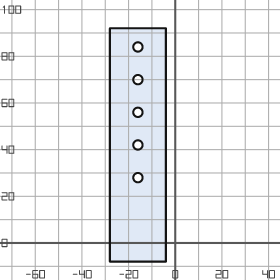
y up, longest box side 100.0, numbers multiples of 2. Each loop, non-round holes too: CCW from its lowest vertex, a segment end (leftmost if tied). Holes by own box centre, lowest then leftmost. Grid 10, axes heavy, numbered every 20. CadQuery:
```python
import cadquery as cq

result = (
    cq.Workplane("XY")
    .moveTo(-28.0, -8.0)
    .lineTo(-4.0, -8.0)
    .lineTo(-4.0, 92.0)
    .lineTo(-28.0, 92.0)
    .close()
    .moveTo(-16.0, 28.0)
    .circle(2.0)
    .moveTo(-16.0, 42.0)
    .circle(2.0)
    .moveTo(-16.0, 56.0)
    .circle(2.0)
    .moveTo(-16.0, 70.0)
    .circle(2.0)
    .moveTo(-16.0, 84.0)
    .circle(2.0)
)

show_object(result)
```